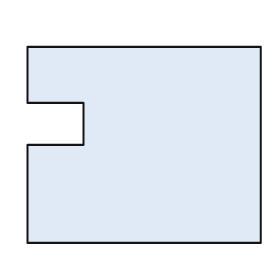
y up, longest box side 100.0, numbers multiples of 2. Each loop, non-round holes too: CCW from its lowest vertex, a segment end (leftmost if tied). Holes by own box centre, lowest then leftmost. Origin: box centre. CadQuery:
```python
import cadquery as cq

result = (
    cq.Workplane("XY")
    .moveTo(-50.0, -42.0)
    .lineTo(50.0, -42.0)
    .lineTo(50.0, 42.0)
    .lineTo(-50.0, 42.0)
    .lineTo(-50.0, 18.0)
    .lineTo(-26.0, 18.0)
    .lineTo(-26.0, 0.0)
    .lineTo(-50.0, 0.0)
    .close()
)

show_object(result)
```